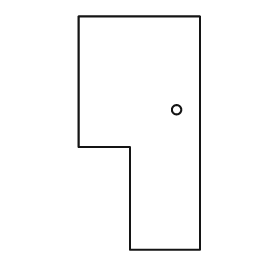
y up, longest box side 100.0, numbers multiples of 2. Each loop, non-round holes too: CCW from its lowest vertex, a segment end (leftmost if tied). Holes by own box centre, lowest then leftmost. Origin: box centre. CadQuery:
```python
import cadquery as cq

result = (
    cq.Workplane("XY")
    .moveTo(-4.0, -50.0)
    .lineTo(26.0, -50.0)
    .lineTo(26.0, 50.0)
    .lineTo(-26.0, 50.0)
    .lineTo(-26.0, -6.0)
    .lineTo(-4.0, -6.0)
    .close()
    .moveTo(16.0, 10.0)
    .circle(2.0)
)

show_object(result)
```